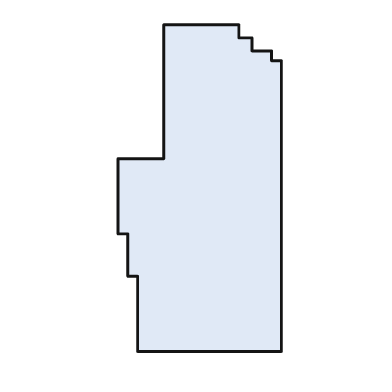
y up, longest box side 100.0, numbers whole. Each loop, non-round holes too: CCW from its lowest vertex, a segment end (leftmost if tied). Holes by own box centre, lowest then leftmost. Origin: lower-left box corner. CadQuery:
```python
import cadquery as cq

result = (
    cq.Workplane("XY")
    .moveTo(6.0, 0.0)
    .lineTo(50.0, 0.0)
    .lineTo(50.0, 89.0)
    .lineTo(47.0, 89.0)
    .lineTo(47.0, 92.0)
    .lineTo(41.0, 92.0)
    .lineTo(41.0, 96.0)
    .lineTo(37.0, 96.0)
    .lineTo(37.0, 100.0)
    .lineTo(14.0, 100.0)
    .lineTo(14.0, 59.0)
    .lineTo(0.0, 59.0)
    .lineTo(0.0, 36.0)
    .lineTo(3.0, 36.0)
    .lineTo(3.0, 23.0)
    .lineTo(6.0, 23.0)
    .close()
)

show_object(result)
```